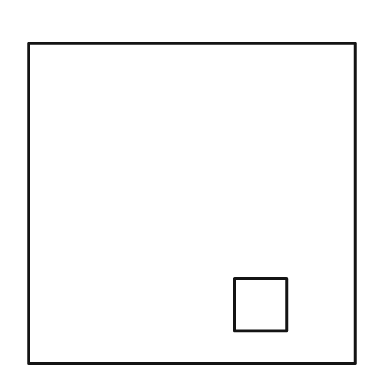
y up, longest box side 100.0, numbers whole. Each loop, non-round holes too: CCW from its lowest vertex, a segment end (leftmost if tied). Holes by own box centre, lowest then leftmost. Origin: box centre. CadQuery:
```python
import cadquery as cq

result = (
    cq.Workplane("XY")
    .moveTo(-50.0, -49.0)
    .lineTo(50.0, -49.0)
    .lineTo(50.0, 49.0)
    .lineTo(-50.0, 49.0)
    .close()
    .moveTo(13.0, -39.0)
    .lineTo(29.0, -39.0)
    .lineTo(29.0, -23.0)
    .lineTo(13.0, -23.0)
    .close()
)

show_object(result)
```